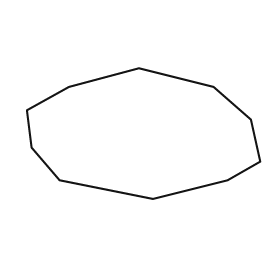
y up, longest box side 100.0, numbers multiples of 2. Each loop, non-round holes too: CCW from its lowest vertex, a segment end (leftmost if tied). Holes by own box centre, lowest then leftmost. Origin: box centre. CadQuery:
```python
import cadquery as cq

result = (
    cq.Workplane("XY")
    .moveTo(4.0, -28.0)
    .lineTo(36.0, -20.0)
    .lineTo(50.0, -12.0)
    .lineTo(46.0, 6.0)
    .lineTo(30.0, 20.0)
    .lineTo(-2.0, 28.0)
    .lineTo(-32.0, 20.0)
    .lineTo(-50.0, 10.0)
    .lineTo(-48.0, -6.0)
    .lineTo(-36.0, -20.0)
    .close()
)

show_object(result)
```